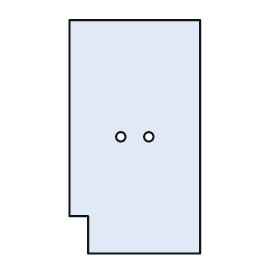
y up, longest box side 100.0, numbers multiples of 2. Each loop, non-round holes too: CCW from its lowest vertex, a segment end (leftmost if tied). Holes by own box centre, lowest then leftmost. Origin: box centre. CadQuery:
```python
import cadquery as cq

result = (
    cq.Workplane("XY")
    .moveTo(-20.0, -50.0)
    .lineTo(28.0, -50.0)
    .lineTo(28.0, 50.0)
    .lineTo(-28.0, 50.0)
    .lineTo(-28.0, -34.0)
    .lineTo(-20.0, -34.0)
    .close()
    .moveTo(-6.0, 0.0)
    .circle(2.0)
    .moveTo(6.0, 0.0)
    .circle(2.0)
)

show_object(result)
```